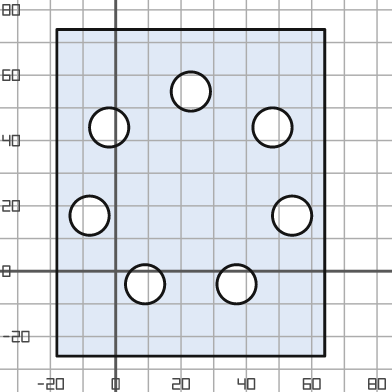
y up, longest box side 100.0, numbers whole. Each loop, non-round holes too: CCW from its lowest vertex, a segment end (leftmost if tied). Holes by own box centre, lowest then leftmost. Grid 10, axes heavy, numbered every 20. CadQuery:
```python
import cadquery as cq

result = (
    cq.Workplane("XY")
    .moveTo(-18.0, -26.0)
    .lineTo(64.0, -26.0)
    .lineTo(64.0, 74.0)
    .lineTo(-18.0, 74.0)
    .close()
    .moveTo(9.0, -4.0)
    .circle(6.0)
    .moveTo(37.0, -4.0)
    .circle(6.0)
    .moveTo(-8.0, 17.0)
    .circle(6.0)
    .moveTo(54.0, 17.0)
    .circle(6.0)
    .moveTo(-2.0, 44.0)
    .circle(6.0)
    .moveTo(48.0, 44.0)
    .circle(6.0)
    .moveTo(23.0, 55.0)
    .circle(6.0)
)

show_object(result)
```